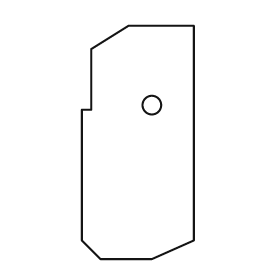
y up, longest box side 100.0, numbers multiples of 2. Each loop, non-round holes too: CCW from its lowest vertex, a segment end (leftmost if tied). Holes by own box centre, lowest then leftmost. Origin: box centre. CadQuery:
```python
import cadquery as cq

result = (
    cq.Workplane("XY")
    .moveTo(-16.0, -50.0)
    .lineTo(6.0, -50.0)
    .lineTo(24.0, -42.0)
    .lineTo(24.0, 50.0)
    .lineTo(-4.0, 50.0)
    .lineTo(-20.0, 40.0)
    .lineTo(-20.0, 14.0)
    .lineTo(-24.0, 14.0)
    .lineTo(-24.0, -42.0)
    .close()
    .moveTo(6.0, 16.0)
    .circle(4.0)
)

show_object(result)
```